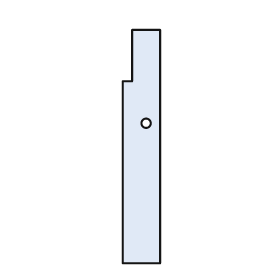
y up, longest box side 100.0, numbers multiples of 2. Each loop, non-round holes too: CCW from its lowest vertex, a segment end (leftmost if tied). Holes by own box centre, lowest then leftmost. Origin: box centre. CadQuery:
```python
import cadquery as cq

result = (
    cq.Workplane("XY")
    .moveTo(-8.0, -50.0)
    .lineTo(8.0, -50.0)
    .lineTo(8.0, 50.0)
    .lineTo(-4.0, 50.0)
    .lineTo(-4.0, 28.0)
    .lineTo(-8.0, 28.0)
    .close()
    .moveTo(2.0, 10.0)
    .circle(2.0)
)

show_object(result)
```